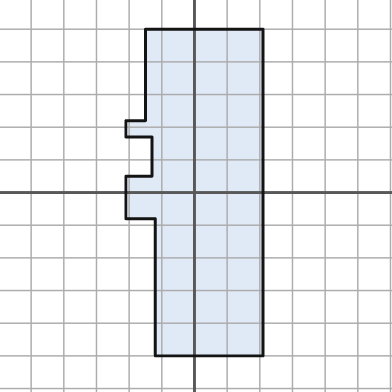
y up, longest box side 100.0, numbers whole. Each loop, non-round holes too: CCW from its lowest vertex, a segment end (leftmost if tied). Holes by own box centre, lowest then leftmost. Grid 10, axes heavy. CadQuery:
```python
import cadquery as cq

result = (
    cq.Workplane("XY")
    .moveTo(-12.0, -50.0)
    .lineTo(21.0, -50.0)
    .lineTo(21.0, 50.0)
    .lineTo(-15.0, 50.0)
    .lineTo(-15.0, 22.0)
    .lineTo(-21.0, 22.0)
    .lineTo(-21.0, 17.0)
    .lineTo(-13.0, 17.0)
    .lineTo(-13.0, 5.0)
    .lineTo(-21.0, 5.0)
    .lineTo(-21.0, -8.0)
    .lineTo(-12.0, -8.0)
    .close()
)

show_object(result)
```